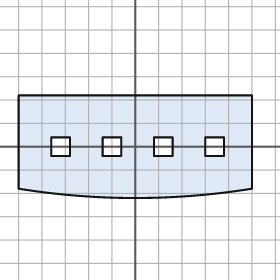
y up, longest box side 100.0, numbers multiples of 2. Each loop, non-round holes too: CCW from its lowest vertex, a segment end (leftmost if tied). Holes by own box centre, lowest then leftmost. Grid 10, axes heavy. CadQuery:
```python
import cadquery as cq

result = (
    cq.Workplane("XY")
    .moveTo(-50.0, -18.0)
    .threePointArc((0.0, -22.0), (50.0, -18.0))
    .lineTo(50.0, 22.0)
    .lineTo(-50.0, 22.0)
    .close()
    .moveTo(-36.0, -4.0)
    .lineTo(-28.0, -4.0)
    .lineTo(-28.0, 4.0)
    .lineTo(-36.0, 4.0)
    .close()
    .moveTo(-14.0, -4.0)
    .lineTo(-6.0, -4.0)
    .lineTo(-6.0, 4.0)
    .lineTo(-14.0, 4.0)
    .close()
    .moveTo(8.0, -4.0)
    .lineTo(16.0, -4.0)
    .lineTo(16.0, 4.0)
    .lineTo(8.0, 4.0)
    .close()
    .moveTo(30.0, -4.0)
    .lineTo(38.0, -4.0)
    .lineTo(38.0, 4.0)
    .lineTo(30.0, 4.0)
    .close()
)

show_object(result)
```